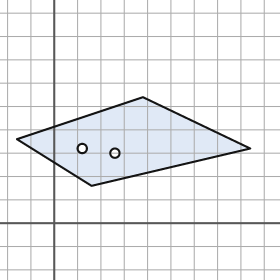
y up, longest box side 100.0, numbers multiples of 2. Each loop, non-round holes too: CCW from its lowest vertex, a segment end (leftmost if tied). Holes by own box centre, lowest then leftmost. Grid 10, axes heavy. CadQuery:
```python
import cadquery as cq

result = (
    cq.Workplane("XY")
    .moveTo(16.0, 16.0)
    .lineTo(84.0, 32.0)
    .lineTo(38.0, 54.0)
    .lineTo(-16.0, 36.0)
    .close()
    .moveTo(26.0, 30.0)
    .circle(2.0)
    .moveTo(12.0, 32.0)
    .circle(2.0)
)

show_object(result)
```